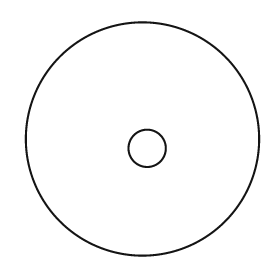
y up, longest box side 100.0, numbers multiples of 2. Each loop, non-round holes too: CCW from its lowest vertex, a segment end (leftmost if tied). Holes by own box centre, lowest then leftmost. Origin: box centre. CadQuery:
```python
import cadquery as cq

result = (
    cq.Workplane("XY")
    .moveTo(0.0, 0.0)
    .circle(50.0)
    .moveTo(2.0, -4.0)
    .circle(8.0)
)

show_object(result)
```